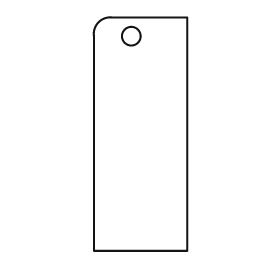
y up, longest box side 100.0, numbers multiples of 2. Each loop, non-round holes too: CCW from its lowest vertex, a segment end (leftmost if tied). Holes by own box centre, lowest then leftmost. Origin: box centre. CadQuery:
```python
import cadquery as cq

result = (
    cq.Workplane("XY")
    .moveTo(-20.0, -50.0)
    .lineTo(20.0, -50.0)
    .lineTo(20.0, 50.0)
    .lineTo(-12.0, 50.0)
    .threePointArc((-18.0, 48.0), (-20.0, 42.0))
    .close()
    .moveTo(-4.0, 42.0)
    .circle(4.0)
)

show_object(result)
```